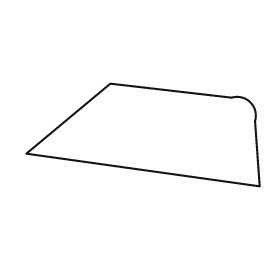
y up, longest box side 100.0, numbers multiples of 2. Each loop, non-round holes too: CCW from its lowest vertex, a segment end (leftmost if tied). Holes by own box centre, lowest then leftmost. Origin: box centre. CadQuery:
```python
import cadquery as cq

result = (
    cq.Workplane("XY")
    .moveTo(50.0, -22.0)
    .lineTo(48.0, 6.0)
    .threePointArc((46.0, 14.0), (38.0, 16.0))
    .lineTo(-14.0, 22.0)
    .lineTo(-50.0, -8.0)
    .close()
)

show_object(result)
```